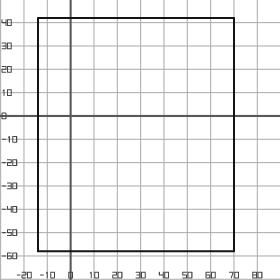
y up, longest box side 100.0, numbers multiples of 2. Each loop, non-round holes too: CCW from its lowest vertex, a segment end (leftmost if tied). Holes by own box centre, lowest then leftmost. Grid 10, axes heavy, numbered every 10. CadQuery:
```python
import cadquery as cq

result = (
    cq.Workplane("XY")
    .moveTo(-14.0, -58.0)
    .lineTo(70.0, -58.0)
    .lineTo(70.0, 42.0)
    .lineTo(-14.0, 42.0)
    .close()
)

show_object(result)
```